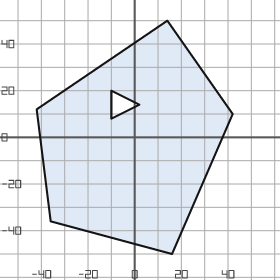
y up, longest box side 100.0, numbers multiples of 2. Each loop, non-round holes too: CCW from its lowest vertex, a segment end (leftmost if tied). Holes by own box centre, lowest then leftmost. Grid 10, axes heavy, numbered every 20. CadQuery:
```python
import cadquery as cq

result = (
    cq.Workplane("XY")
    .moveTo(16.0, -50.0)
    .lineTo(42.0, 10.0)
    .lineTo(14.0, 50.0)
    .lineTo(-42.0, 12.0)
    .lineTo(-36.0, -36.0)
    .close()
    .moveTo(-10.0, 8.0)
    .lineTo(2.0, 14.0)
    .lineTo(-10.0, 20.0)
    .close()
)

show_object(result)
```